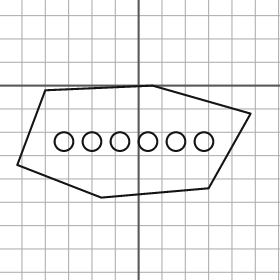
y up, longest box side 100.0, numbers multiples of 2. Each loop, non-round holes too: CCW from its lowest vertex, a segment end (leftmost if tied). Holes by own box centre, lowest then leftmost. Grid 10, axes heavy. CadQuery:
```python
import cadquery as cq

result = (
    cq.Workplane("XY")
    .moveTo(-16.0, -48.0)
    .lineTo(30.0, -44.0)
    .lineTo(48.0, -12.0)
    .lineTo(6.0, 0.0)
    .lineTo(-40.0, -2.0)
    .lineTo(-52.0, -34.0)
    .close()
    .moveTo(-32.0, -24.0)
    .circle(4.0)
    .moveTo(-20.0, -24.0)
    .circle(4.0)
    .moveTo(-8.0, -24.0)
    .circle(4.0)
    .moveTo(4.0, -24.0)
    .circle(4.0)
    .moveTo(16.0, -24.0)
    .circle(4.0)
    .moveTo(28.0, -24.0)
    .circle(4.0)
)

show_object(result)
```